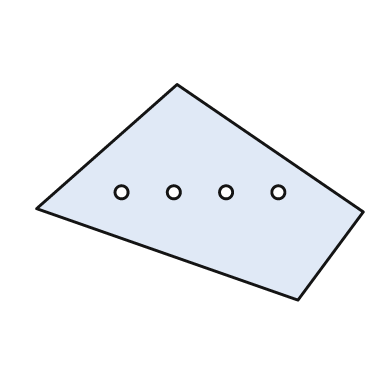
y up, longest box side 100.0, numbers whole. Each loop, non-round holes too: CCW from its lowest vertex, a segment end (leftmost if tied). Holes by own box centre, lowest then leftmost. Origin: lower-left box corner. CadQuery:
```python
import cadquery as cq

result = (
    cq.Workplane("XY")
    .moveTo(80.0, 0.0)
    .lineTo(100.0, 27.0)
    .lineTo(43.0, 66.0)
    .lineTo(0.0, 28.0)
    .close()
    .moveTo(26.0, 33.0)
    .circle(2.0)
    .moveTo(42.0, 33.0)
    .circle(2.0)
    .moveTo(58.0, 33.0)
    .circle(2.0)
    .moveTo(74.0, 33.0)
    .circle(2.0)
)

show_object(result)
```